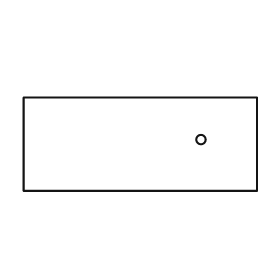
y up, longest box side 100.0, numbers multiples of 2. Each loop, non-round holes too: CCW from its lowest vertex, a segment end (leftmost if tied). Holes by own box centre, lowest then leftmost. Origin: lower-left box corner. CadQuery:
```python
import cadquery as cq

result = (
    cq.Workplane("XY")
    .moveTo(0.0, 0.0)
    .lineTo(100.0, 0.0)
    .lineTo(100.0, 40.0)
    .lineTo(0.0, 40.0)
    .close()
    .moveTo(76.0, 22.0)
    .circle(2.0)
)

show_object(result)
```